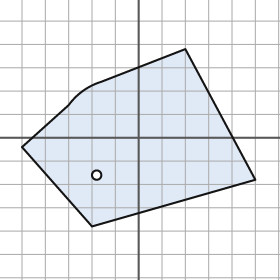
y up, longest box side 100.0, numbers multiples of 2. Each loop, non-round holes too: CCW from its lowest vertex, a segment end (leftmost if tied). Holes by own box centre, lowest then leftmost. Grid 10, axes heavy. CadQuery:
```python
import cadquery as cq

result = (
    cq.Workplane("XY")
    .moveTo(-20.0, -38.0)
    .lineTo(50.0, -18.0)
    .lineTo(20.0, 38.0)
    .lineTo(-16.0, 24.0)
    .threePointArc((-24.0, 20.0), (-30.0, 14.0))
    .lineTo(-50.0, -4.0)
    .close()
    .moveTo(-18.0, -16.0)
    .circle(2.0)
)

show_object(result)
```